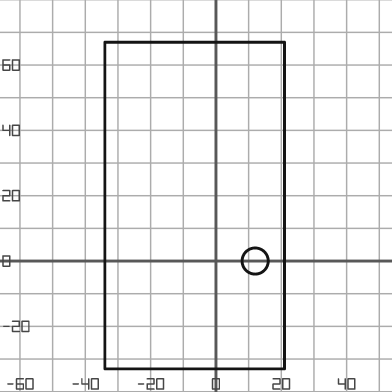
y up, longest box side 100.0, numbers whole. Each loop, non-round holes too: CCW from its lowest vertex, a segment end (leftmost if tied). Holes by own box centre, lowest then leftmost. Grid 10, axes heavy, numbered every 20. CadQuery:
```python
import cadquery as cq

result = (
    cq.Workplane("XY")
    .moveTo(-34.0, -33.0)
    .lineTo(21.0, -33.0)
    .lineTo(21.0, 67.0)
    .lineTo(-34.0, 67.0)
    .close()
    .moveTo(12.0, 0.0)
    .circle(4.0)
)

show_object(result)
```